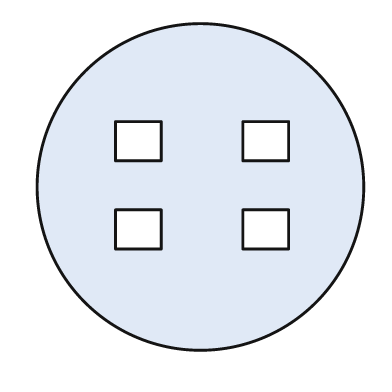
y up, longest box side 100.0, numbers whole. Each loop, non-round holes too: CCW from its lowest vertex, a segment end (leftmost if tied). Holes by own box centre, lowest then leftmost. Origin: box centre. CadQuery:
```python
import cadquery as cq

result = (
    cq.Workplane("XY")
    .moveTo(0.0, 0.0)
    .circle(50.0)
    .moveTo(-26.0, -19.0)
    .lineTo(-12.0, -19.0)
    .lineTo(-12.0, -7.0)
    .lineTo(-26.0, -7.0)
    .close()
    .moveTo(13.0, -19.0)
    .lineTo(27.0, -19.0)
    .lineTo(27.0, -7.0)
    .lineTo(13.0, -7.0)
    .close()
    .moveTo(-26.0, 8.0)
    .lineTo(-12.0, 8.0)
    .lineTo(-12.0, 20.0)
    .lineTo(-26.0, 20.0)
    .close()
    .moveTo(13.0, 8.0)
    .lineTo(27.0, 8.0)
    .lineTo(27.0, 20.0)
    .lineTo(13.0, 20.0)
    .close()
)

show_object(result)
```